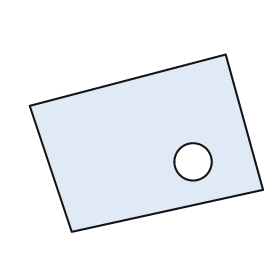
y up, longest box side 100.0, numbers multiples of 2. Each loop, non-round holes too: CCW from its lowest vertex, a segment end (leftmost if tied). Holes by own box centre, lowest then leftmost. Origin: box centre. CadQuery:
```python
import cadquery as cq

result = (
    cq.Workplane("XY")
    .moveTo(-32.0, -38.0)
    .lineTo(50.0, -20.0)
    .lineTo(34.0, 38.0)
    .lineTo(-50.0, 16.0)
    .close()
    .moveTo(20.0, -8.0)
    .circle(8.0)
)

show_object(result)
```